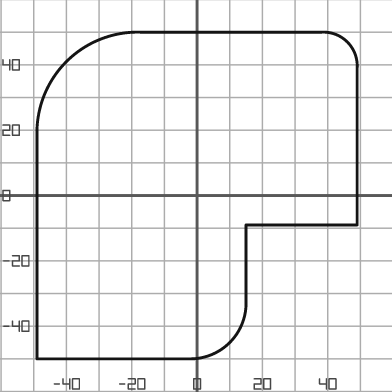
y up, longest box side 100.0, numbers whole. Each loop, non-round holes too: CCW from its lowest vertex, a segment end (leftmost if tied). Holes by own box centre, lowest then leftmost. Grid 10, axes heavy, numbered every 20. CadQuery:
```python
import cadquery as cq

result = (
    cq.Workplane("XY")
    .moveTo(-49.0, -50.0)
    .lineTo(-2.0, -50.0)
    .threePointArc((10.0, -45.0), (15.0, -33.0))
    .lineTo(15.0, -9.0)
    .lineTo(49.0, -9.0)
    .lineTo(49.0, 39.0)
    .threePointArc((46.0, 47.0), (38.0, 50.0))
    .lineTo(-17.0, 50.0)
    .threePointArc((-40.0, 41.0), (-49.0, 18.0))
    .close()
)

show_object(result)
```